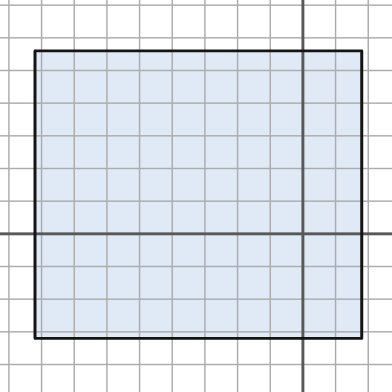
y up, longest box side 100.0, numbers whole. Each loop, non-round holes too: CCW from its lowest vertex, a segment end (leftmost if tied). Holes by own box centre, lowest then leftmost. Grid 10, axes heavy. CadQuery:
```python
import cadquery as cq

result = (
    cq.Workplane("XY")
    .moveTo(-82.0, -32.0)
    .lineTo(18.0, -32.0)
    .lineTo(18.0, 56.0)
    .lineTo(-82.0, 56.0)
    .close()
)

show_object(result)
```